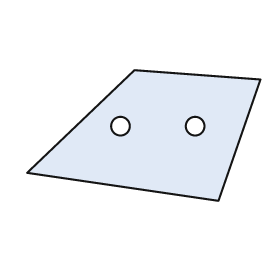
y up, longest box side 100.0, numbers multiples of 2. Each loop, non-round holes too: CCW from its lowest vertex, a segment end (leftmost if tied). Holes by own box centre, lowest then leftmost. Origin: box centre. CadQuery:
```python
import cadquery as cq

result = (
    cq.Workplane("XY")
    .moveTo(32.0, -28.0)
    .lineTo(50.0, 24.0)
    .lineTo(-4.0, 28.0)
    .lineTo(-50.0, -16.0)
    .close()
    .moveTo(-10.0, 4.0)
    .circle(4.0)
    .moveTo(22.0, 4.0)
    .circle(4.0)
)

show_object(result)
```